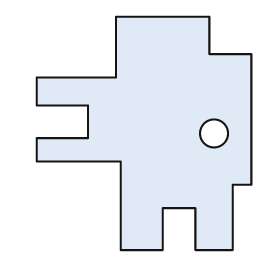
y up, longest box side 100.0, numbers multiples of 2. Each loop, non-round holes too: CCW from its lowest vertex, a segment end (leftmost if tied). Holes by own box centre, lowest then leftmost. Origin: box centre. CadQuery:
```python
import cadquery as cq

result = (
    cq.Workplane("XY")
    .moveTo(-10.0, -50.0)
    .lineTo(8.0, -50.0)
    .lineTo(8.0, -32.0)
    .lineTo(22.0, -32.0)
    .lineTo(22.0, -50.0)
    .lineTo(38.0, -50.0)
    .lineTo(38.0, -22.0)
    .lineTo(46.0, -22.0)
    .lineTo(46.0, 34.0)
    .lineTo(28.0, 34.0)
    .lineTo(28.0, 50.0)
    .lineTo(-12.0, 50.0)
    .lineTo(-12.0, 24.0)
    .lineTo(-46.0, 24.0)
    .lineTo(-46.0, 12.0)
    .lineTo(-24.0, 12.0)
    .lineTo(-24.0, -2.0)
    .lineTo(-46.0, -2.0)
    .lineTo(-46.0, -12.0)
    .lineTo(-10.0, -12.0)
    .close()
    .moveTo(30.0, 0.0)
    .circle(6.0)
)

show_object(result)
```